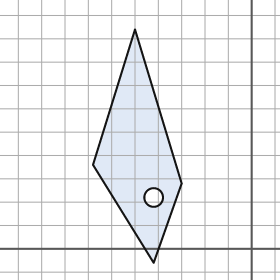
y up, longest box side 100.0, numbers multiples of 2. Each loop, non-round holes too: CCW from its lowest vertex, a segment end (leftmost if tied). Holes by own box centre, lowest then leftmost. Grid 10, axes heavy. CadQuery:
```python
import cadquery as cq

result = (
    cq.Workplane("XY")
    .moveTo(-42.0, -6.0)
    .lineTo(-30.0, 28.0)
    .lineTo(-50.0, 94.0)
    .lineTo(-68.0, 36.0)
    .close()
    .moveTo(-42.0, 22.0)
    .circle(4.0)
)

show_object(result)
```